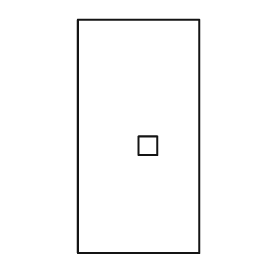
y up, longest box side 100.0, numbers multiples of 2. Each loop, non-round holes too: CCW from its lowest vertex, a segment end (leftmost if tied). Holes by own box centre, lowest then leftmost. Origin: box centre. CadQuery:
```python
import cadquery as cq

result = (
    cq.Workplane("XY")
    .moveTo(-26.0, -50.0)
    .lineTo(26.0, -50.0)
    .lineTo(26.0, 50.0)
    .lineTo(-26.0, 50.0)
    .close()
    .moveTo(0.0, -8.0)
    .lineTo(8.0, -8.0)
    .lineTo(8.0, 0.0)
    .lineTo(0.0, 0.0)
    .close()
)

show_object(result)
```